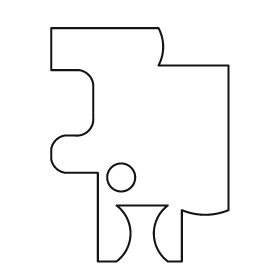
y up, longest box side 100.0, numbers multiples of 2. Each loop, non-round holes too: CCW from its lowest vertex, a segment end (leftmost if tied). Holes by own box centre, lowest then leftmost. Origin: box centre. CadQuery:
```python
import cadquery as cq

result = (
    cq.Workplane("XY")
    .moveTo(-18.0, -50.0)
    .lineTo(-10.0, -50.0)
    .threePointArc((-4.0, -38.0), (-10.0, -26.0))
    .lineTo(12.0, -26.0)
    .threePointArc((6.0, -38.0), (12.0, -50.0))
    .lineTo(18.0, -50.0)
    .lineTo(18.0, -28.0)
    .threePointArc((28.0, -30.0), (38.0, -28.0))
    .lineTo(38.0, 34.0)
    .lineTo(8.0, 34.0)
    .threePointArc((10.0, 42.0), (8.0, 50.0))
    .lineTo(-38.0, 50.0)
    .lineTo(-38.0, 32.0)
    .lineTo(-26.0, 32.0)
    .threePointArc((-22.0, 30.0), (-20.0, 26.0))
    .lineTo(-20.0, 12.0)
    .threePointArc((-22.0, 6.0), (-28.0, 4.0))
    .lineTo(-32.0, 4.0)
    .threePointArc((-36.0, 2.0), (-38.0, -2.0))
    .lineTo(-38.0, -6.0)
    .threePointArc((-36.0, -10.0), (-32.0, -12.0))
    .lineTo(-18.0, -12.0)
    .close()
    .moveTo(-8.0, -14.0)
    .circle(6.0)
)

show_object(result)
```